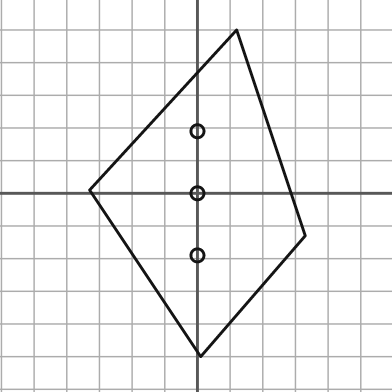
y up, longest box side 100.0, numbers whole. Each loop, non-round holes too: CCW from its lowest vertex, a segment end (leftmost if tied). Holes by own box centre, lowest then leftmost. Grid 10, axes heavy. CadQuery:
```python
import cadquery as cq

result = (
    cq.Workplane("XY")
    .moveTo(1.0, -50.0)
    .lineTo(33.0, -13.0)
    .lineTo(12.0, 50.0)
    .lineTo(-33.0, 1.0)
    .close()
    .moveTo(0.0, -19.0)
    .circle(2.0)
    .moveTo(0.0, 0.0)
    .circle(2.0)
    .moveTo(0.0, 19.0)
    .circle(2.0)
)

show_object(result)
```